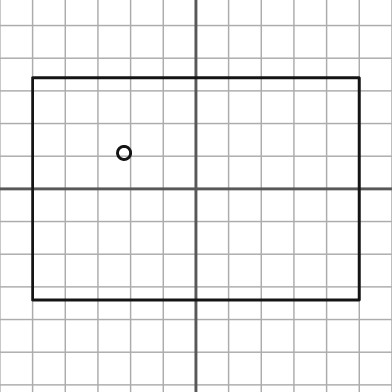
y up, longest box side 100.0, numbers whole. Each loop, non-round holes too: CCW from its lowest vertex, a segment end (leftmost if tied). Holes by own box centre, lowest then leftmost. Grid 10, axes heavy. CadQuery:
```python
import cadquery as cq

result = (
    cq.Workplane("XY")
    .moveTo(-50.0, -34.0)
    .lineTo(50.0, -34.0)
    .lineTo(50.0, 34.0)
    .lineTo(-50.0, 34.0)
    .close()
    .moveTo(-22.0, 11.0)
    .circle(2.0)
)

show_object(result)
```